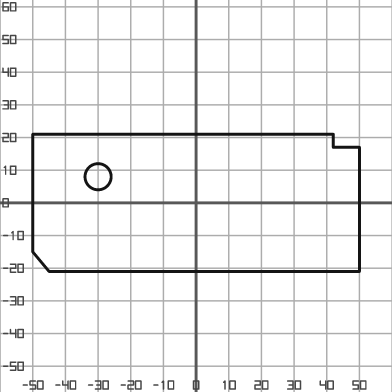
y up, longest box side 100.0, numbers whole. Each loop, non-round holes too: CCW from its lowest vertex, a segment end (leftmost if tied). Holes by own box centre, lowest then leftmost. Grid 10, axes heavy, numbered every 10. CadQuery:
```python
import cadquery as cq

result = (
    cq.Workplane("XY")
    .moveTo(-45.0, -21.0)
    .lineTo(50.0, -21.0)
    .lineTo(50.0, 17.0)
    .lineTo(42.0, 17.0)
    .lineTo(42.0, 21.0)
    .lineTo(-50.0, 21.0)
    .lineTo(-50.0, -15.0)
    .close()
    .moveTo(-30.0, 8.0)
    .circle(4.0)
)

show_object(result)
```